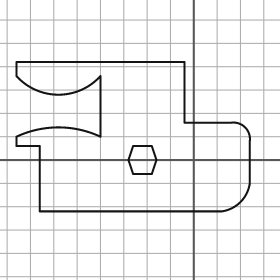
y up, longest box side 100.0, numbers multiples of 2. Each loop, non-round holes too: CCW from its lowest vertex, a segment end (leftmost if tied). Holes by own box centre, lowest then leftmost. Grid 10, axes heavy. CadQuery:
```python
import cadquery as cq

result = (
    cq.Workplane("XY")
    .moveTo(-66.0, -22.0)
    .lineTo(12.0, -22.0)
    .threePointArc((20.0, -18.0), (24.0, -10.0))
    .lineTo(24.0, 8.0)
    .threePointArc((22.0, 14.0), (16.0, 16.0))
    .lineTo(-4.0, 16.0)
    .lineTo(-4.0, 42.0)
    .lineTo(-76.0, 42.0)
    .lineTo(-76.0, 36.0)
    .threePointArc((-58.0, 28.0), (-40.0, 36.0))
    .lineTo(-40.0, 10.0)
    .threePointArc((-58.0, 14.0), (-76.0, 10.0))
    .lineTo(-76.0, 6.0)
    .lineTo(-66.0, 6.0)
    .close()
    .moveTo(-26.0, -6.0)
    .lineTo(-18.0, -6.0)
    .lineTo(-16.0, 0.0)
    .lineTo(-18.0, 6.0)
    .lineTo(-26.0, 6.0)
    .lineTo(-28.0, 0.0)
    .close()
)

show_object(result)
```